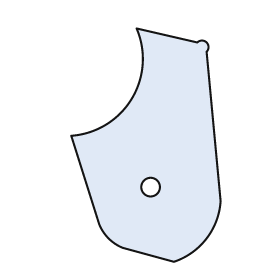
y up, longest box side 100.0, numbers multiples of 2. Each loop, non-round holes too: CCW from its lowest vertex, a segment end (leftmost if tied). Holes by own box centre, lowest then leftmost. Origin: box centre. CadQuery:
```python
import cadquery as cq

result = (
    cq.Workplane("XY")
    .moveTo(12.0, -50.0)
    .threePointArc((26.0, -40.0), (32.0, -24.0))
    .lineTo(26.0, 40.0)
    .threePointArc((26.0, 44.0), (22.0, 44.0))
    .lineTo(-4.0, 50.0)
    .threePointArc((-6.0, 20.0), (-32.0, 4.0))
    .lineTo(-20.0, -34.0)
    .threePointArc((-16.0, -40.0), (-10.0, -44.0))
    .close()
    .moveTo(2.0, -18.0)
    .circle(4.0)
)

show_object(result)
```